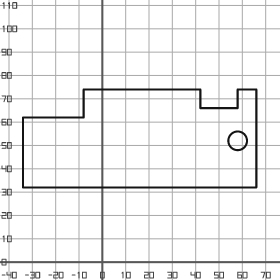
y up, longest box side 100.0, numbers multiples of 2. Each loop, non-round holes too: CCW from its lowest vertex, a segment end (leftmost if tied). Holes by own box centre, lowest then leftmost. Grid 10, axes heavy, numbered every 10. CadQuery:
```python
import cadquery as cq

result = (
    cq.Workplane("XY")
    .moveTo(-34.0, 32.0)
    .lineTo(66.0, 32.0)
    .lineTo(66.0, 74.0)
    .lineTo(58.0, 74.0)
    .lineTo(58.0, 66.0)
    .lineTo(42.0, 66.0)
    .lineTo(42.0, 74.0)
    .lineTo(-8.0, 74.0)
    .lineTo(-8.0, 62.0)
    .lineTo(-34.0, 62.0)
    .close()
    .moveTo(58.0, 52.0)
    .circle(4.0)
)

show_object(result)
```